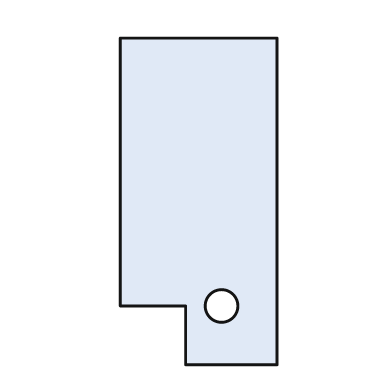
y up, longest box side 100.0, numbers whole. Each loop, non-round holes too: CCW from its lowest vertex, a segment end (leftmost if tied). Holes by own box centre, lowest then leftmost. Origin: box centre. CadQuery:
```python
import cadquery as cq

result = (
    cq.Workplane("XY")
    .moveTo(-4.0, -50.0)
    .lineTo(24.0, -50.0)
    .lineTo(24.0, 50.0)
    .lineTo(-24.0, 50.0)
    .lineTo(-24.0, -32.0)
    .lineTo(-4.0, -32.0)
    .close()
    .moveTo(7.0, -32.0)
    .circle(5.0)
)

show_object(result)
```